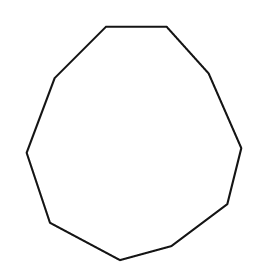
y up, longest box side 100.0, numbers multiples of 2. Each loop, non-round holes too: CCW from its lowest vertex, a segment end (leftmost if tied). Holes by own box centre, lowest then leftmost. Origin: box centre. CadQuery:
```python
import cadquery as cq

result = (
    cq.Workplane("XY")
    .moveTo(-6.0, -50.0)
    .lineTo(16.0, -44.0)
    .lineTo(40.0, -26.0)
    .lineTo(46.0, -2.0)
    .lineTo(32.0, 30.0)
    .lineTo(14.0, 50.0)
    .lineTo(-12.0, 50.0)
    .lineTo(-34.0, 28.0)
    .lineTo(-46.0, -4.0)
    .lineTo(-36.0, -34.0)
    .close()
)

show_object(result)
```